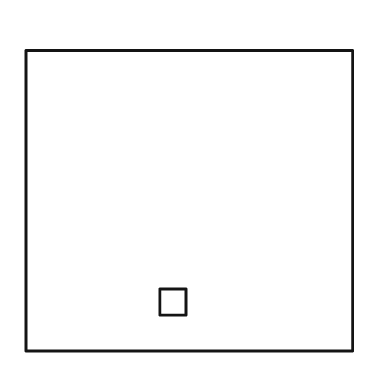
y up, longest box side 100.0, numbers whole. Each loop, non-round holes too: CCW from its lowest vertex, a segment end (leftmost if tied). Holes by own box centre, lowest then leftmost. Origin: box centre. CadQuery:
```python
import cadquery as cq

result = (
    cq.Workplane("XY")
    .moveTo(-50.0, -46.0)
    .lineTo(50.0, -46.0)
    .lineTo(50.0, 46.0)
    .lineTo(-50.0, 46.0)
    .close()
    .moveTo(-9.0, -35.0)
    .lineTo(-1.0, -35.0)
    .lineTo(-1.0, -27.0)
    .lineTo(-9.0, -27.0)
    .close()
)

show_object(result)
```